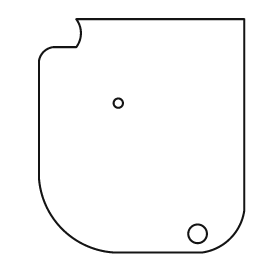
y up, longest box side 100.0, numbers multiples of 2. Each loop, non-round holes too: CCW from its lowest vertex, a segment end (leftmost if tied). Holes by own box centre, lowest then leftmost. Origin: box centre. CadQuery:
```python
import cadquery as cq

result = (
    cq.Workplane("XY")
    .moveTo(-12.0, -50.0)
    .lineTo(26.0, -50.0)
    .threePointArc((38.0, -44.0), (44.0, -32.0))
    .lineTo(44.0, 50.0)
    .lineTo(-28.0, 50.0)
    .threePointArc((-26.0, 44.0), (-28.0, 38.0))
    .lineTo(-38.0, 38.0)
    .threePointArc((-42.0, 36.0), (-44.0, 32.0))
    .lineTo(-44.0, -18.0)
    .threePointArc((-34.0, -40.0), (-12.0, -50.0))
    .close()
    .moveTo(24.0, -42.0)
    .circle(4.0)
    .moveTo(-10.0, 14.0)
    .circle(2.0)
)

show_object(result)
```